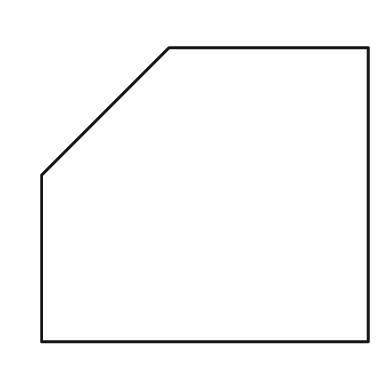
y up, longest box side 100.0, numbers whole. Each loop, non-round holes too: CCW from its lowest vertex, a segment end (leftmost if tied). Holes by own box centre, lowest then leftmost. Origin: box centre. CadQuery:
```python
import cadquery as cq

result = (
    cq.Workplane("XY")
    .moveTo(-50.0, -45.0)
    .lineTo(50.0, -45.0)
    .lineTo(50.0, 45.0)
    .lineTo(-11.0, 45.0)
    .lineTo(-50.0, 6.0)
    .close()
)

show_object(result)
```